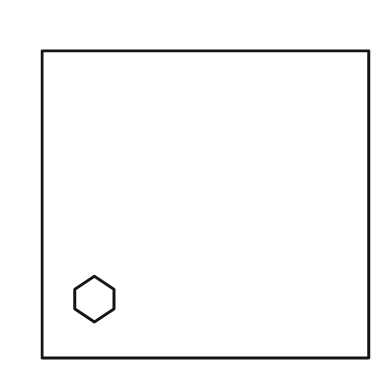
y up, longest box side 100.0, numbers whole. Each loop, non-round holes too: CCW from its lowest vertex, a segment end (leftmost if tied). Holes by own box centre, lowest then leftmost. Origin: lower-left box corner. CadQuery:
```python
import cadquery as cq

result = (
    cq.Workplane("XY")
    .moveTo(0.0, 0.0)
    .lineTo(100.0, 0.0)
    .lineTo(100.0, 94.0)
    .lineTo(0.0, 94.0)
    .close()
    .moveTo(16.0, 11.0)
    .lineTo(22.0, 15.0)
    .lineTo(22.0, 21.0)
    .lineTo(16.0, 25.0)
    .lineTo(10.0, 21.0)
    .lineTo(10.0, 15.0)
    .close()
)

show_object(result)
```